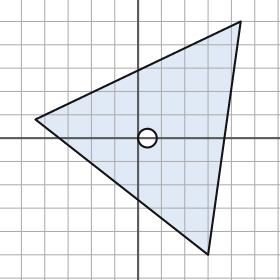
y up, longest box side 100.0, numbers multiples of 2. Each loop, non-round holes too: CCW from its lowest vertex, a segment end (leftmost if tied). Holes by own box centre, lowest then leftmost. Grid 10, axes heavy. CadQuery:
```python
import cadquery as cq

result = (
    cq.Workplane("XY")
    .moveTo(30.0, -50.0)
    .lineTo(44.0, 50.0)
    .lineTo(-44.0, 8.0)
    .close()
    .moveTo(4.0, 0.0)
    .circle(4.0)
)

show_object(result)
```